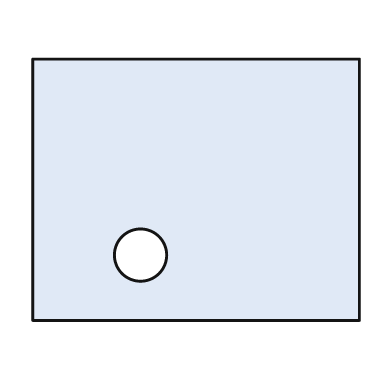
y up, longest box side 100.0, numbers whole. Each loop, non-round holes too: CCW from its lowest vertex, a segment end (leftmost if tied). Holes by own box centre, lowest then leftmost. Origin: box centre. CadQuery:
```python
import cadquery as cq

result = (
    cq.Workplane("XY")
    .moveTo(-50.0, -40.0)
    .lineTo(50.0, -40.0)
    .lineTo(50.0, 40.0)
    .lineTo(-50.0, 40.0)
    .close()
    .moveTo(-17.0, -20.0)
    .circle(8.0)
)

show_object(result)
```